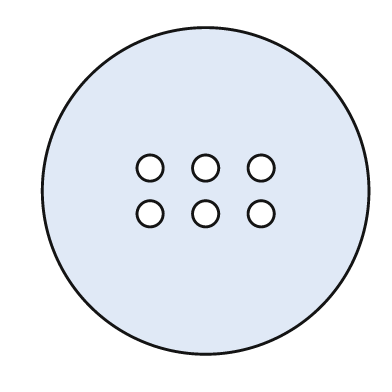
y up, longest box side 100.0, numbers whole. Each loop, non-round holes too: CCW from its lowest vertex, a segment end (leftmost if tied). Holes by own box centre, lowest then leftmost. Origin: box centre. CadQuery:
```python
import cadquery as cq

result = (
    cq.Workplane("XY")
    .moveTo(0.0, 0.0)
    .circle(50.0)
    .moveTo(-17.0, -7.0)
    .circle(4.0)
    .moveTo(0.0, -7.0)
    .circle(4.0)
    .moveTo(17.0, -7.0)
    .circle(4.0)
    .moveTo(-17.0, 7.0)
    .circle(4.0)
    .moveTo(0.0, 7.0)
    .circle(4.0)
    .moveTo(17.0, 7.0)
    .circle(4.0)
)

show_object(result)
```